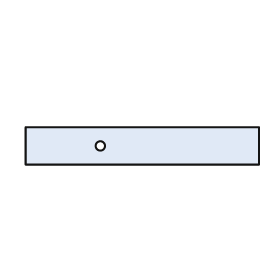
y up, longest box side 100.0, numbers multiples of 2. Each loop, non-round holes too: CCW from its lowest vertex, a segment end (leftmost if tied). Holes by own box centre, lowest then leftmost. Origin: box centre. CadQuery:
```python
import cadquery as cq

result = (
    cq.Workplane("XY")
    .moveTo(-50.0, -8.0)
    .lineTo(50.0, -8.0)
    .lineTo(50.0, 8.0)
    .lineTo(-50.0, 8.0)
    .close()
    .moveTo(-18.0, 0.0)
    .circle(2.0)
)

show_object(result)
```